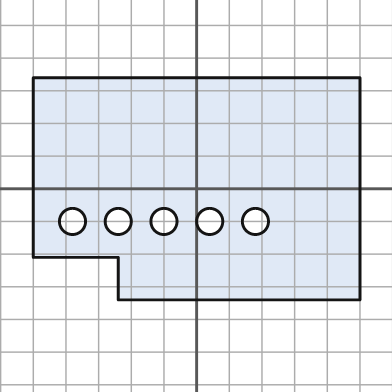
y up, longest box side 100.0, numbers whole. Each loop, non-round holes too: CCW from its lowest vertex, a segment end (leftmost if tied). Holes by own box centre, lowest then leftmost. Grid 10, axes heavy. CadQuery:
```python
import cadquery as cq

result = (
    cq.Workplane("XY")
    .moveTo(-24.0, -34.0)
    .lineTo(50.0, -34.0)
    .lineTo(50.0, 34.0)
    .lineTo(-50.0, 34.0)
    .lineTo(-50.0, -21.0)
    .lineTo(-24.0, -21.0)
    .close()
    .moveTo(-38.0, -10.0)
    .circle(4.0)
    .moveTo(-24.0, -10.0)
    .circle(4.0)
    .moveTo(-10.0, -10.0)
    .circle(4.0)
    .moveTo(4.0, -10.0)
    .circle(4.0)
    .moveTo(18.0, -10.0)
    .circle(4.0)
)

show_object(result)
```